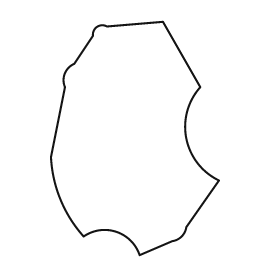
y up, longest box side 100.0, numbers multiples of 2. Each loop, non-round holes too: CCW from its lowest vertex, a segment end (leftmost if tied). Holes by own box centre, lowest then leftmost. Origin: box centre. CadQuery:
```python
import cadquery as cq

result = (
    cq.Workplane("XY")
    .moveTo(2.0, -50.0)
    .lineTo(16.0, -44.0)
    .threePointArc((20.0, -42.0), (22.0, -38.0))
    .lineTo(36.0, -18.0)
    .threePointArc((22.0, 0.0), (28.0, 22.0))
    .lineTo(12.0, 50.0)
    .lineTo(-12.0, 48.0)
    .threePointArc((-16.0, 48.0), (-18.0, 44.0))
    .lineTo(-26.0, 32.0)
    .threePointArc((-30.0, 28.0), (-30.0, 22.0))
    .lineTo(-36.0, -8.0)
    .threePointArc((-32.0, -26.0), (-22.0, -42.0))
    .threePointArc((-8.0, -40.0), (2.0, -50.0))
    .close()
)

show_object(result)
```